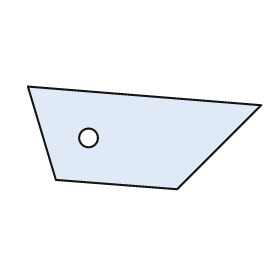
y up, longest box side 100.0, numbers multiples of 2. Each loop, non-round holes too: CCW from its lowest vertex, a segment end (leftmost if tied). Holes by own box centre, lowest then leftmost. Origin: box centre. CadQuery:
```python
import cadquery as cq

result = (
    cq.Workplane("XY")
    .moveTo(14.0, -22.0)
    .lineTo(50.0, 14.0)
    .lineTo(-50.0, 22.0)
    .lineTo(-38.0, -18.0)
    .close()
    .moveTo(-24.0, 0.0)
    .circle(4.0)
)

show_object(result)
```